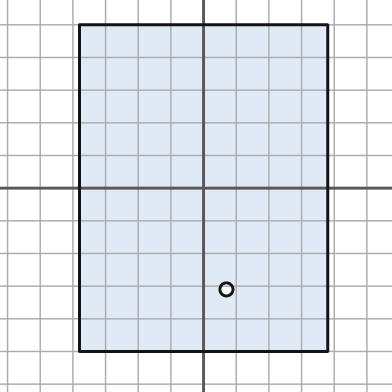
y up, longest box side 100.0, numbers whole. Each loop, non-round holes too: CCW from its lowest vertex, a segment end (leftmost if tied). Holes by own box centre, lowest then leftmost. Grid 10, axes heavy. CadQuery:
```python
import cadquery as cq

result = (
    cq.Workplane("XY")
    .moveTo(-38.0, -50.0)
    .lineTo(38.0, -50.0)
    .lineTo(38.0, 50.0)
    .lineTo(-38.0, 50.0)
    .close()
    .moveTo(7.0, -31.0)
    .circle(2.0)
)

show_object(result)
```